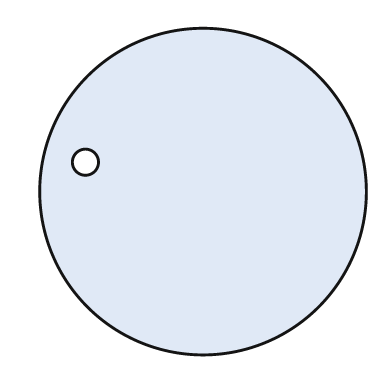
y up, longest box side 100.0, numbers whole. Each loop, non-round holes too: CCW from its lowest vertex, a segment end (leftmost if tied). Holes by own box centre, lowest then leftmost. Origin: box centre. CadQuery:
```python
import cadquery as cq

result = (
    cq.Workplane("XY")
    .moveTo(0.0, 0.0)
    .circle(50.0)
    .moveTo(-36.0, 9.0)
    .circle(4.0)
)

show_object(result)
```